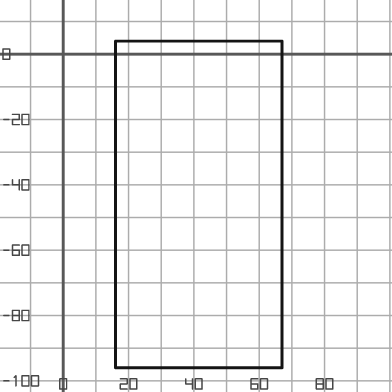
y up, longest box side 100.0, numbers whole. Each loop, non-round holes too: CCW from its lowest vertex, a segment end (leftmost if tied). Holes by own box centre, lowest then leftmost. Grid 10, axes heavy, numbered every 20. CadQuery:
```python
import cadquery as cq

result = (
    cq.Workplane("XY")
    .moveTo(16.0, -96.0)
    .lineTo(67.0, -96.0)
    .lineTo(67.0, 4.0)
    .lineTo(16.0, 4.0)
    .close()
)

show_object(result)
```